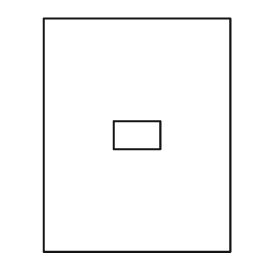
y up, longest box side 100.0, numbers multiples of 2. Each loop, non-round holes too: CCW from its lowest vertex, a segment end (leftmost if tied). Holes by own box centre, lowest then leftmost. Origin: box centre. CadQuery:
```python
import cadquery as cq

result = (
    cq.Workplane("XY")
    .moveTo(-40.0, -50.0)
    .lineTo(40.0, -50.0)
    .lineTo(40.0, 50.0)
    .lineTo(-40.0, 50.0)
    .close()
    .moveTo(-10.0, -6.0)
    .lineTo(10.0, -6.0)
    .lineTo(10.0, 6.0)
    .lineTo(-10.0, 6.0)
    .close()
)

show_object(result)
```